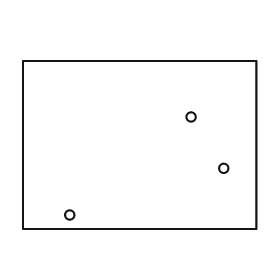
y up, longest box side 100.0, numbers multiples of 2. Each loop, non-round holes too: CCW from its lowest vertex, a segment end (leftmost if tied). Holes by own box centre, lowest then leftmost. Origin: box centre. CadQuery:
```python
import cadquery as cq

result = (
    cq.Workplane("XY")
    .moveTo(-50.0, -36.0)
    .lineTo(50.0, -36.0)
    .lineTo(50.0, 36.0)
    .lineTo(-50.0, 36.0)
    .close()
    .moveTo(-30.0, -30.0)
    .circle(2.0)
    .moveTo(36.0, -10.0)
    .circle(2.0)
    .moveTo(22.0, 12.0)
    .circle(2.0)
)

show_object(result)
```